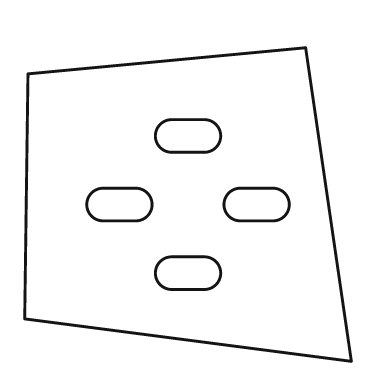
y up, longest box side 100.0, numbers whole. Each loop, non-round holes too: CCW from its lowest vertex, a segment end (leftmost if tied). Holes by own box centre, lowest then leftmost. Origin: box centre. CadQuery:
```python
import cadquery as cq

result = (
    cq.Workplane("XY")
    .moveTo(50.0, -48.0)
    .lineTo(36.0, 48.0)
    .lineTo(-49.0, 40.0)
    .lineTo(-50.0, -35.0)
    .close()
    .moveTo(-5.0, -26.0)
    .lineTo(5.0, -26.0)
    .threePointArc((10.0, -21.0), (5.0, -16.0))
    .lineTo(-5.0, -16.0)
    .threePointArc((-10.0, -21.0), (-5.0, -26.0))
    .close()
    .moveTo(-26.0, -5.0)
    .lineTo(-16.0, -5.0)
    .threePointArc((-11.0, 0.0), (-16.0, 5.0))
    .lineTo(-26.0, 5.0)
    .threePointArc((-31.0, 0.0), (-26.0, -5.0))
    .close()
    .moveTo(16.0, -5.0)
    .lineTo(26.0, -5.0)
    .threePointArc((31.0, 0.0), (26.0, 5.0))
    .lineTo(16.0, 5.0)
    .threePointArc((11.0, 0.0), (16.0, -5.0))
    .close()
    .moveTo(-5.0, 16.0)
    .lineTo(5.0, 16.0)
    .threePointArc((10.0, 21.0), (5.0, 26.0))
    .lineTo(-5.0, 26.0)
    .threePointArc((-10.0, 21.0), (-5.0, 16.0))
    .close()
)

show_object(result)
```